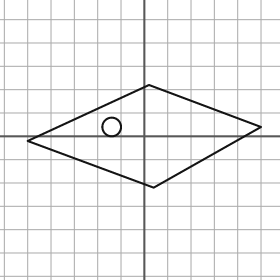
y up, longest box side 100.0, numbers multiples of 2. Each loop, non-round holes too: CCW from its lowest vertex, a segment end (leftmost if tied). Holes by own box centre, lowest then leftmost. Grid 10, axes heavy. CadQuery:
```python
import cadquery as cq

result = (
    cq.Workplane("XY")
    .moveTo(4.0, -22.0)
    .lineTo(50.0, 4.0)
    .lineTo(2.0, 22.0)
    .lineTo(-50.0, -2.0)
    .close()
    .moveTo(-14.0, 4.0)
    .circle(4.0)
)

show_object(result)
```